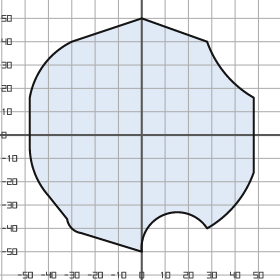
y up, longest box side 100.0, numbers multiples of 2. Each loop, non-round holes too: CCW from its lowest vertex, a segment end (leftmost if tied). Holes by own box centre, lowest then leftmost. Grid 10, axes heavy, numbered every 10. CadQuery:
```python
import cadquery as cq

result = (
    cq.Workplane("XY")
    .moveTo(0.0, -50.0)
    .threePointArc((10.0, -34.0), (28.0, -40.0))
    .threePointArc((40.0, -30.0), (48.0, -16.0))
    .lineTo(48.0, 16.0)
    .threePointArc((36.0, 26.0), (28.0, 40.0))
    .lineTo(0.0, 50.0)
    .lineTo(-30.0, 40.0)
    .threePointArc((-42.0, 30.0), (-48.0, 16.0))
    .lineTo(-48.0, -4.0)
    .threePointArc((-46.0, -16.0), (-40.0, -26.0))
    .lineTo(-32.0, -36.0)
    .threePointArc((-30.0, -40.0), (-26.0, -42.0))
    .close()
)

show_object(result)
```